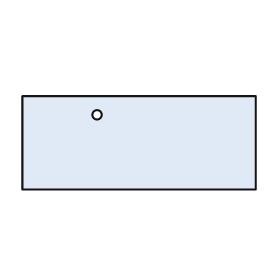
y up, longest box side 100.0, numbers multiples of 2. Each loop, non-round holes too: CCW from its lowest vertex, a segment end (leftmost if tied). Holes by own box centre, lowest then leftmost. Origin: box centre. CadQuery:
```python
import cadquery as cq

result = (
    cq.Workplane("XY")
    .moveTo(-50.0, -20.0)
    .lineTo(50.0, -20.0)
    .lineTo(50.0, 20.0)
    .lineTo(-50.0, 20.0)
    .close()
    .moveTo(-18.0, 12.0)
    .circle(2.0)
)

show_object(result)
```